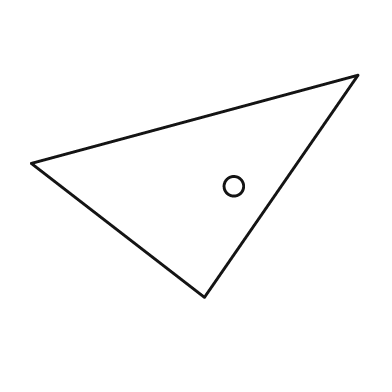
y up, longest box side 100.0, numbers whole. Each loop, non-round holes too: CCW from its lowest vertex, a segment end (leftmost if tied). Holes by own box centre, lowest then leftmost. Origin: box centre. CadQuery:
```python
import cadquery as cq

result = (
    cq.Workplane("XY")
    .moveTo(3.0, -34.0)
    .lineTo(50.0, 34.0)
    .lineTo(-50.0, 7.0)
    .close()
    .moveTo(12.0, 0.0)
    .circle(3.0)
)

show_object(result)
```